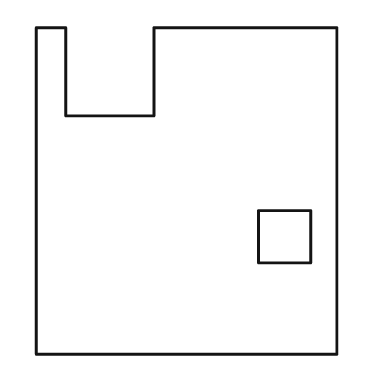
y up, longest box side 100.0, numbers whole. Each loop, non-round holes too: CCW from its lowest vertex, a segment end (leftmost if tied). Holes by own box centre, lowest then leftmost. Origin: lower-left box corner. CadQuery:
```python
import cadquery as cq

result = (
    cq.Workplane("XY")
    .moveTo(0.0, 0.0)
    .lineTo(92.0, 0.0)
    .lineTo(92.0, 100.0)
    .lineTo(36.0, 100.0)
    .lineTo(36.0, 73.0)
    .lineTo(9.0, 73.0)
    .lineTo(9.0, 100.0)
    .lineTo(0.0, 100.0)
    .close()
    .moveTo(68.0, 28.0)
    .lineTo(84.0, 28.0)
    .lineTo(84.0, 44.0)
    .lineTo(68.0, 44.0)
    .close()
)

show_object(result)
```